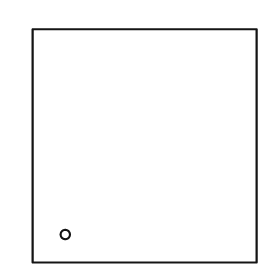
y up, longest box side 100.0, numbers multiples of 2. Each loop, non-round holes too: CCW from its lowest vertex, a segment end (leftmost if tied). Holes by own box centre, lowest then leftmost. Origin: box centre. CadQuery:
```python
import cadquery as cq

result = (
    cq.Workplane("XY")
    .moveTo(-48.0, -50.0)
    .lineTo(48.0, -50.0)
    .lineTo(48.0, 50.0)
    .lineTo(-48.0, 50.0)
    .close()
    .moveTo(-34.0, -38.0)
    .circle(2.0)
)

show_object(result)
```